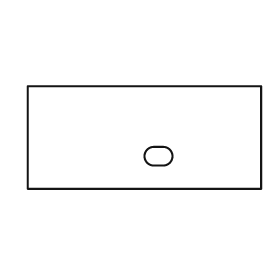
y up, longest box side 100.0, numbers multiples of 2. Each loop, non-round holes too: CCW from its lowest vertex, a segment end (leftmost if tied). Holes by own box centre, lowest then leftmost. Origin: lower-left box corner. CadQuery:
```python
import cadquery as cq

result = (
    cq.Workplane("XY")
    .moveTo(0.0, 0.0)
    .lineTo(100.0, 0.0)
    .lineTo(100.0, 44.0)
    .lineTo(0.0, 44.0)
    .close()
    .moveTo(54.0, 10.0)
    .lineTo(58.0, 10.0)
    .threePointArc((62.0, 14.0), (58.0, 18.0))
    .lineTo(54.0, 18.0)
    .threePointArc((50.0, 14.0), (54.0, 10.0))
    .close()
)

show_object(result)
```